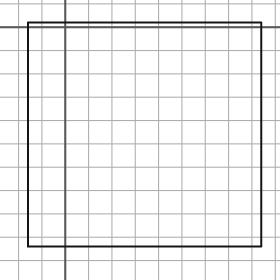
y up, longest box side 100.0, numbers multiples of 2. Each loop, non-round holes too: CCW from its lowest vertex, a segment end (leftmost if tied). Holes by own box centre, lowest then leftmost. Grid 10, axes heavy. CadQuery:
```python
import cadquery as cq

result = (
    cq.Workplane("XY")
    .moveTo(-16.0, -94.0)
    .lineTo(84.0, -94.0)
    .lineTo(84.0, 2.0)
    .lineTo(-16.0, 2.0)
    .close()
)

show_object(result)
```